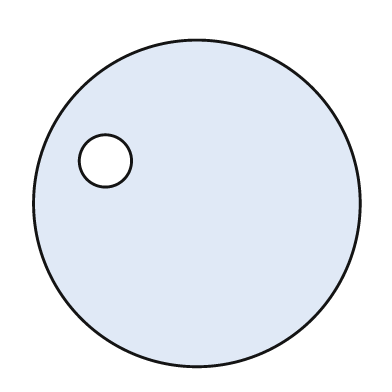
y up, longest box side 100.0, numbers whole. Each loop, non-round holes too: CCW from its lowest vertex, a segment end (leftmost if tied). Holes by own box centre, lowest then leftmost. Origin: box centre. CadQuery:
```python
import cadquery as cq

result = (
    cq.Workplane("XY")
    .moveTo(0.0, 0.0)
    .circle(50.0)
    .moveTo(-28.0, 13.0)
    .circle(8.0)
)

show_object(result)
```